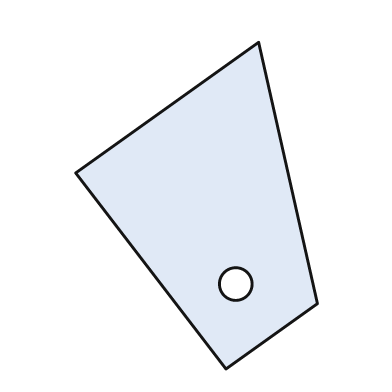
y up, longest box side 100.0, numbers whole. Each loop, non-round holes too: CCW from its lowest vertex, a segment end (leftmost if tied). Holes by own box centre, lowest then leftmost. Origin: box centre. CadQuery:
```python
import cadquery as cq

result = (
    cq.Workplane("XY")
    .moveTo(9.0, -50.0)
    .lineTo(37.0, -30.0)
    .lineTo(19.0, 50.0)
    .lineTo(-37.0, 10.0)
    .close()
    .moveTo(12.0, -24.0)
    .circle(5.0)
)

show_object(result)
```